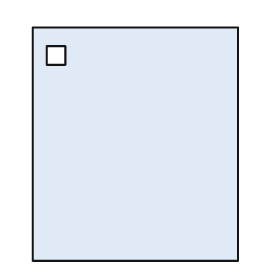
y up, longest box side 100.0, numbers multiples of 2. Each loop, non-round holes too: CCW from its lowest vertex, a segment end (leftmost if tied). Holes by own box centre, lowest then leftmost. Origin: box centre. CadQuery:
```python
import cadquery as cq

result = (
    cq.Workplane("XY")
    .moveTo(-44.0, -50.0)
    .lineTo(44.0, -50.0)
    .lineTo(44.0, 50.0)
    .lineTo(-44.0, 50.0)
    .close()
    .moveTo(-38.0, 34.0)
    .lineTo(-30.0, 34.0)
    .lineTo(-30.0, 42.0)
    .lineTo(-38.0, 42.0)
    .close()
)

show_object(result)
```